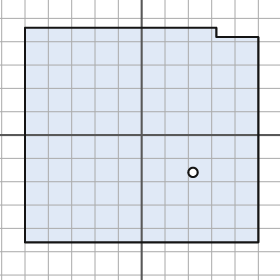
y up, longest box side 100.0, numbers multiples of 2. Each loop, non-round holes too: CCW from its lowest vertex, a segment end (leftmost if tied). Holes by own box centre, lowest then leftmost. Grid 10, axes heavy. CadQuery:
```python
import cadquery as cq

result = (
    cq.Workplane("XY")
    .moveTo(-50.0, -46.0)
    .lineTo(50.0, -46.0)
    .lineTo(50.0, 42.0)
    .lineTo(32.0, 42.0)
    .lineTo(32.0, 46.0)
    .lineTo(-50.0, 46.0)
    .close()
    .moveTo(22.0, -16.0)
    .circle(2.0)
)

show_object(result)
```